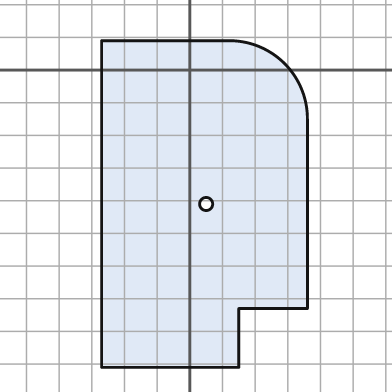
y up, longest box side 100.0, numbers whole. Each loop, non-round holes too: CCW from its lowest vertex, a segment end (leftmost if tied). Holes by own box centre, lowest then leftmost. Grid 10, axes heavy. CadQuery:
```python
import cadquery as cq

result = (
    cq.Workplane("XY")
    .moveTo(-27.0, -91.0)
    .lineTo(15.0, -91.0)
    .lineTo(15.0, -73.0)
    .lineTo(36.0, -73.0)
    .lineTo(36.0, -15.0)
    .threePointArc((29.0, 2.0), (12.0, 9.0))
    .lineTo(-27.0, 9.0)
    .close()
    .moveTo(5.0, -41.0)
    .circle(2.0)
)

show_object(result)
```